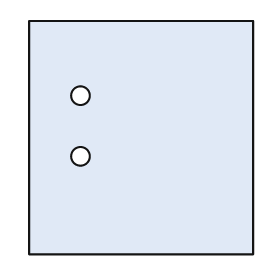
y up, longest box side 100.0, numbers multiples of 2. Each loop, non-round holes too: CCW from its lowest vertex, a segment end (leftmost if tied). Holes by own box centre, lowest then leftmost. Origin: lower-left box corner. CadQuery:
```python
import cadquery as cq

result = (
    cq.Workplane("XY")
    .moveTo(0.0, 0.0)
    .lineTo(96.0, 0.0)
    .lineTo(96.0, 100.0)
    .lineTo(0.0, 100.0)
    .close()
    .moveTo(22.0, 42.0)
    .circle(4.0)
    .moveTo(22.0, 68.0)
    .circle(4.0)
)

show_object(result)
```